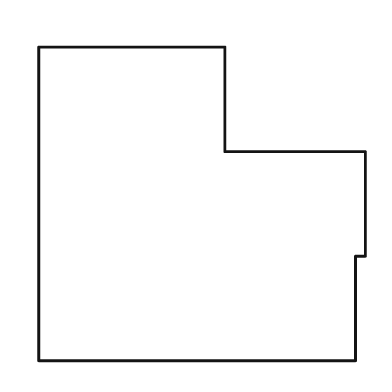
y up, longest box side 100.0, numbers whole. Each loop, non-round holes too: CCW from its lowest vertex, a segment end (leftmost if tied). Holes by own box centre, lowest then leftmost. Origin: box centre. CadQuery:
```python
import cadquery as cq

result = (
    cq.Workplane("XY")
    .moveTo(-50.0, -48.0)
    .lineTo(47.0, -48.0)
    .lineTo(47.0, -16.0)
    .lineTo(50.0, -16.0)
    .lineTo(50.0, 16.0)
    .lineTo(7.0, 16.0)
    .lineTo(7.0, 48.0)
    .lineTo(-50.0, 48.0)
    .close()
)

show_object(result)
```